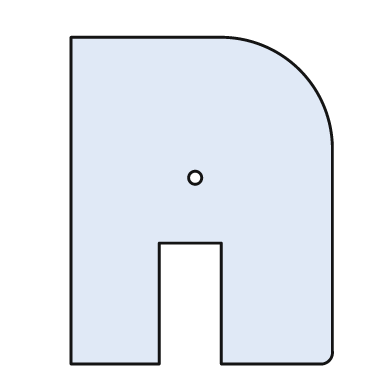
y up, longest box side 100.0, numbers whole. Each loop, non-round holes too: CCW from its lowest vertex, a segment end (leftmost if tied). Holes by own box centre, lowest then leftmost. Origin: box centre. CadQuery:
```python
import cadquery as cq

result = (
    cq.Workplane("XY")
    .moveTo(-40.0, -50.0)
    .lineTo(-13.0, -50.0)
    .lineTo(-13.0, -13.0)
    .lineTo(6.0, -13.0)
    .lineTo(6.0, -50.0)
    .lineTo(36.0, -50.0)
    .threePointArc((39.0, -49.0), (40.0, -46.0))
    .lineTo(40.0, 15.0)
    .threePointArc((30.0, 40.0), (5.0, 50.0))
    .lineTo(-40.0, 50.0)
    .close()
    .moveTo(-2.0, 7.0)
    .circle(2.0)
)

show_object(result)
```